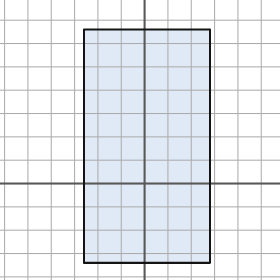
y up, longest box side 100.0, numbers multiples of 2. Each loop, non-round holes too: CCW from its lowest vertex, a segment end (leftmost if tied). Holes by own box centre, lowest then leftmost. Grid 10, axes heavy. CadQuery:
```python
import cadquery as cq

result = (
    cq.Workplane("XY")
    .moveTo(-26.0, -34.0)
    .lineTo(28.0, -34.0)
    .lineTo(28.0, 66.0)
    .lineTo(-26.0, 66.0)
    .close()
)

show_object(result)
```